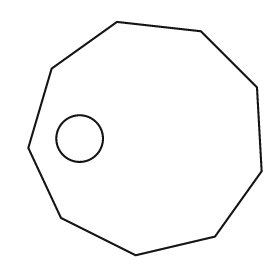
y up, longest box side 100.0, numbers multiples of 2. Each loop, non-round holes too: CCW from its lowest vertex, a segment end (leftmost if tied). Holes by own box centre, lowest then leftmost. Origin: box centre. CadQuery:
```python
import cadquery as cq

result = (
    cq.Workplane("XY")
    .moveTo(-4.0, -50.0)
    .lineTo(30.0, -42.0)
    .lineTo(50.0, -14.0)
    .lineTo(48.0, 22.0)
    .lineTo(24.0, 46.0)
    .lineTo(-12.0, 50.0)
    .lineTo(-40.0, 30.0)
    .lineTo(-50.0, -4.0)
    .lineTo(-36.0, -34.0)
    .close()
    .moveTo(-28.0, 0.0)
    .circle(10.0)
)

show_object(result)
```